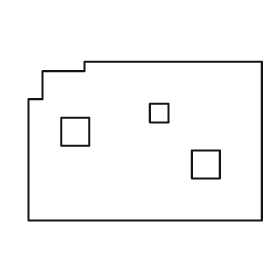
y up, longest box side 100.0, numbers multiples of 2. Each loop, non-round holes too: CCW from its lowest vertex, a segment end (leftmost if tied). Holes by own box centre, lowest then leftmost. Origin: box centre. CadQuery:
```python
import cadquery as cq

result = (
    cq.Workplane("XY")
    .moveTo(-50.0, -34.0)
    .lineTo(50.0, -34.0)
    .lineTo(50.0, 34.0)
    .lineTo(-26.0, 34.0)
    .lineTo(-26.0, 30.0)
    .lineTo(-44.0, 30.0)
    .lineTo(-44.0, 18.0)
    .lineTo(-50.0, 18.0)
    .close()
    .moveTo(20.0, -16.0)
    .lineTo(32.0, -16.0)
    .lineTo(32.0, -4.0)
    .lineTo(20.0, -4.0)
    .close()
    .moveTo(-36.0, -2.0)
    .lineTo(-24.0, -2.0)
    .lineTo(-24.0, 10.0)
    .lineTo(-36.0, 10.0)
    .close()
    .moveTo(2.0, 8.0)
    .lineTo(10.0, 8.0)
    .lineTo(10.0, 16.0)
    .lineTo(2.0, 16.0)
    .close()
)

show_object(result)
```